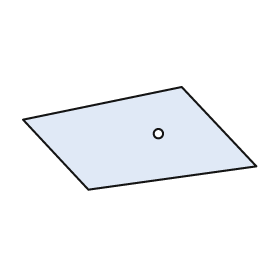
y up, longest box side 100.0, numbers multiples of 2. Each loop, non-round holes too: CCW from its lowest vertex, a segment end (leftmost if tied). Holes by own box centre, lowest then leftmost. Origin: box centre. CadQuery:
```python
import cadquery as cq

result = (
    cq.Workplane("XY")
    .moveTo(-22.0, -22.0)
    .lineTo(50.0, -12.0)
    .lineTo(18.0, 22.0)
    .lineTo(-50.0, 8.0)
    .close()
    .moveTo(8.0, 2.0)
    .circle(2.0)
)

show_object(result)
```